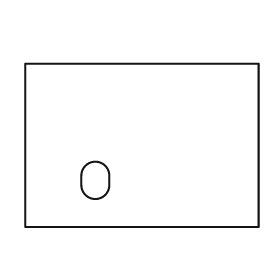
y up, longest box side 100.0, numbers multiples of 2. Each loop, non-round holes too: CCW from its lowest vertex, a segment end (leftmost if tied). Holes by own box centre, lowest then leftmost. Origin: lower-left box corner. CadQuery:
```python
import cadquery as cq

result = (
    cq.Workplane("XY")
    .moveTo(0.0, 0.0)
    .lineTo(100.0, 0.0)
    .lineTo(100.0, 70.0)
    .lineTo(0.0, 70.0)
    .close()
    .moveTo(24.0, 18.0)
    .threePointArc((30.0, 12.0), (36.0, 18.0))
    .lineTo(36.0, 22.0)
    .threePointArc((30.0, 28.0), (24.0, 22.0))
    .close()
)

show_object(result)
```